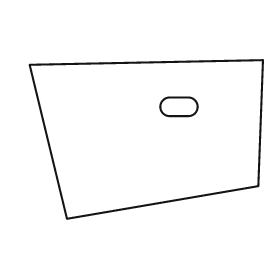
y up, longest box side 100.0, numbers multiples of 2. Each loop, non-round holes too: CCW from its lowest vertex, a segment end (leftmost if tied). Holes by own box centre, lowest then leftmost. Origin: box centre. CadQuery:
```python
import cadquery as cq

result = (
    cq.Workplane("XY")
    .moveTo(-34.0, -34.0)
    .lineTo(48.0, -20.0)
    .lineTo(50.0, 34.0)
    .lineTo(-50.0, 32.0)
    .close()
    .moveTo(10.0, 10.0)
    .lineTo(18.0, 10.0)
    .threePointArc((22.0, 14.0), (18.0, 18.0))
    .lineTo(10.0, 18.0)
    .threePointArc((6.0, 14.0), (10.0, 10.0))
    .close()
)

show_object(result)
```